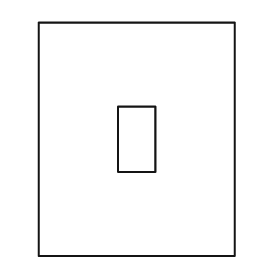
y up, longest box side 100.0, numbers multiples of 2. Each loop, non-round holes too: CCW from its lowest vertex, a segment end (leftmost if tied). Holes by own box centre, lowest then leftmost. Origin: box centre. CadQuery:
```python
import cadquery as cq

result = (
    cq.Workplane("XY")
    .moveTo(-42.0, -50.0)
    .lineTo(42.0, -50.0)
    .lineTo(42.0, 50.0)
    .lineTo(-42.0, 50.0)
    .close()
    .moveTo(-8.0, -14.0)
    .lineTo(8.0, -14.0)
    .lineTo(8.0, 14.0)
    .lineTo(-8.0, 14.0)
    .close()
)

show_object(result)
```